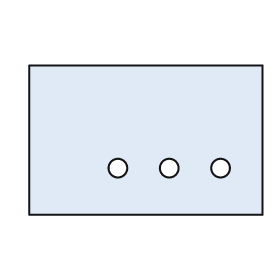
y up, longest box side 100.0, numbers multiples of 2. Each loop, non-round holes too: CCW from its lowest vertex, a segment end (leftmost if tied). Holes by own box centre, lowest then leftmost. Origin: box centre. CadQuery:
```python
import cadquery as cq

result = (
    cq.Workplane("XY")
    .moveTo(-50.0, -32.0)
    .lineTo(50.0, -32.0)
    .lineTo(50.0, 32.0)
    .lineTo(-50.0, 32.0)
    .close()
    .moveTo(-12.0, -12.0)
    .circle(4.0)
    .moveTo(10.0, -12.0)
    .circle(4.0)
    .moveTo(32.0, -12.0)
    .circle(4.0)
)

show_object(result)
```